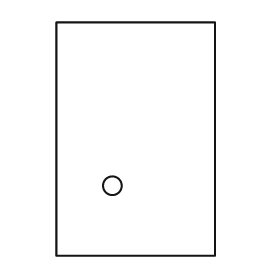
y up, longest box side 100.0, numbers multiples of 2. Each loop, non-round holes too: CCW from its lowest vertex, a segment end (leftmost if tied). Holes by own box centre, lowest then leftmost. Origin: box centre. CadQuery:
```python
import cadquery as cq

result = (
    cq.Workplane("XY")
    .moveTo(-34.0, -50.0)
    .lineTo(34.0, -50.0)
    .lineTo(34.0, 50.0)
    .lineTo(-34.0, 50.0)
    .close()
    .moveTo(-10.0, -20.0)
    .circle(4.0)
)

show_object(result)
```